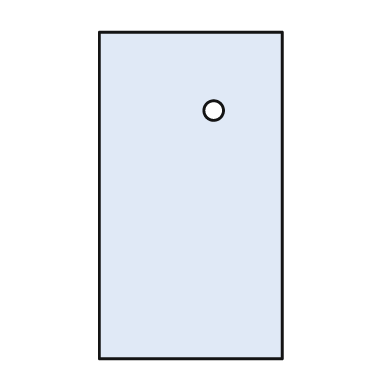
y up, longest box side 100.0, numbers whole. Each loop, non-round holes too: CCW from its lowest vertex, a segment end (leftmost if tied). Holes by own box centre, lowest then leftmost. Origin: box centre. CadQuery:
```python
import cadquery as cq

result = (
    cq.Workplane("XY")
    .moveTo(-28.0, -50.0)
    .lineTo(28.0, -50.0)
    .lineTo(28.0, 50.0)
    .lineTo(-28.0, 50.0)
    .close()
    .moveTo(7.0, 26.0)
    .circle(3.0)
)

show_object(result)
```